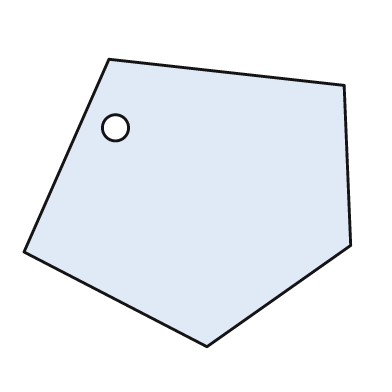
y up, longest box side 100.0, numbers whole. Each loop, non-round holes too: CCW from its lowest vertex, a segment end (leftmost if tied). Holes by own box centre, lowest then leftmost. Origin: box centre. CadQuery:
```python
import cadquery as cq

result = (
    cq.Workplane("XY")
    .moveTo(6.0, -44.0)
    .lineTo(50.0, -13.0)
    .lineTo(48.0, 36.0)
    .lineTo(-24.0, 44.0)
    .lineTo(-50.0, -15.0)
    .close()
    .moveTo(-22.0, 23.0)
    .circle(4.0)
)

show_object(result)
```